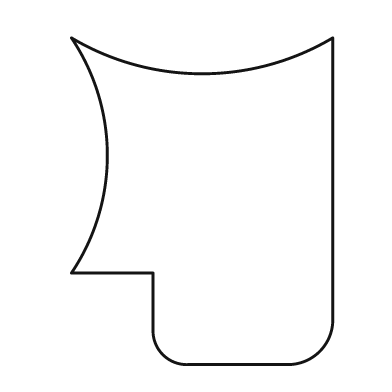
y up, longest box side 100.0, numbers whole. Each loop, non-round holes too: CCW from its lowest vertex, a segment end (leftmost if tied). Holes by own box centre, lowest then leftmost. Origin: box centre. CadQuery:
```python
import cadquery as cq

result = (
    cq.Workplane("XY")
    .moveTo(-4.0, -50.0)
    .lineTo(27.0, -50.0)
    .threePointArc((36.0, -46.0), (40.0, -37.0))
    .lineTo(40.0, 50.0)
    .threePointArc((0.0, 39.0), (-40.0, 50.0))
    .threePointArc((-29.0, 14.0), (-40.0, -22.0))
    .lineTo(-15.0, -22.0)
    .lineTo(-15.0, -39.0)
    .threePointArc((-12.0, -47.0), (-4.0, -50.0))
    .close()
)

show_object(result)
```